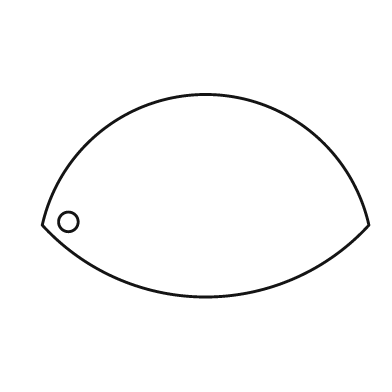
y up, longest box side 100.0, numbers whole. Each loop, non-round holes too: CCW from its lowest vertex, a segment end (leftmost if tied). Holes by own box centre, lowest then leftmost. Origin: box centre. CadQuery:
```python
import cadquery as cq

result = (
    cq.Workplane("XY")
    .moveTo(-50.0, -9.0)
    .threePointArc((0.0, -31.0), (50.0, -9.0))
    .threePointArc((0.0, 31.0), (-50.0, -9.0))
    .close()
    .moveTo(-42.0, -8.0)
    .circle(3.0)
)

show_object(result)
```